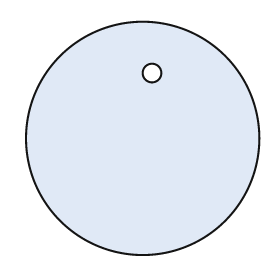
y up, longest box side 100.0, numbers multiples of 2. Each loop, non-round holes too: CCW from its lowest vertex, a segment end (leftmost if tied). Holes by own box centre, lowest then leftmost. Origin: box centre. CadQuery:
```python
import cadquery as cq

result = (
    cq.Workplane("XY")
    .moveTo(0.0, 0.0)
    .circle(50.0)
    .moveTo(4.0, 28.0)
    .circle(4.0)
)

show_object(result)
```